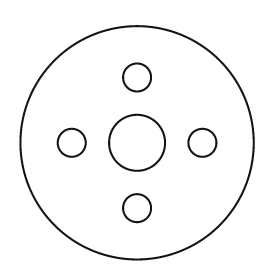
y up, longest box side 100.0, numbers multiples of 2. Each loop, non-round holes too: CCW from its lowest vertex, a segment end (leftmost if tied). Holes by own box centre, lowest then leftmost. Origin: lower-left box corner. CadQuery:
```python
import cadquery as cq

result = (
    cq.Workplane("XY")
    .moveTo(50.0, 50.0)
    .circle(50.0)
    .moveTo(50.0, 22.0)
    .circle(6.0)
    .moveTo(22.0, 50.0)
    .circle(6.0)
    .moveTo(50.0, 50.0)
    .circle(12.0)
    .moveTo(78.0, 50.0)
    .circle(6.0)
    .moveTo(50.0, 78.0)
    .circle(6.0)
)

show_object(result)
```